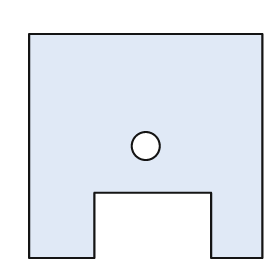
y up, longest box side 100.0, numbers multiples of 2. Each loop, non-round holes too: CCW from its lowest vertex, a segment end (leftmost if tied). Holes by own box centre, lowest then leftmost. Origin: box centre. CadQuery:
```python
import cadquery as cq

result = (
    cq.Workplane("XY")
    .moveTo(-50.0, -48.0)
    .lineTo(-22.0, -48.0)
    .lineTo(-22.0, -20.0)
    .lineTo(28.0, -20.0)
    .lineTo(28.0, -48.0)
    .lineTo(50.0, -48.0)
    .lineTo(50.0, 48.0)
    .lineTo(-50.0, 48.0)
    .close()
    .moveTo(0.0, 0.0)
    .circle(6.0)
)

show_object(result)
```